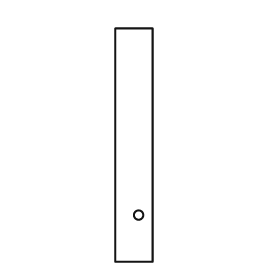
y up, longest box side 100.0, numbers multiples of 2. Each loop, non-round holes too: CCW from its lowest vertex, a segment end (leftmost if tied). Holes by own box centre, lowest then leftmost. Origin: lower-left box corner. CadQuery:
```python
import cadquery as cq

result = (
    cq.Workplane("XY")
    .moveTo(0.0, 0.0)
    .lineTo(16.0, 0.0)
    .lineTo(16.0, 100.0)
    .lineTo(0.0, 100.0)
    .close()
    .moveTo(10.0, 20.0)
    .circle(2.0)
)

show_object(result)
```